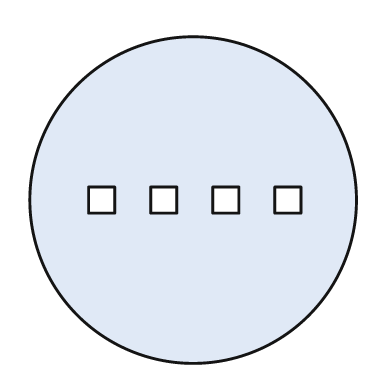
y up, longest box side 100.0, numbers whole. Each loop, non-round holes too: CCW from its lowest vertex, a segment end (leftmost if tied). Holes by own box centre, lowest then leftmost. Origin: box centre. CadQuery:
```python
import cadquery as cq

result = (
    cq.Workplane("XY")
    .moveTo(0.0, 0.0)
    .circle(50.0)
    .moveTo(-32.0, -4.0)
    .lineTo(-24.0, -4.0)
    .lineTo(-24.0, 4.0)
    .lineTo(-32.0, 4.0)
    .close()
    .moveTo(-13.0, -4.0)
    .lineTo(-5.0, -4.0)
    .lineTo(-5.0, 4.0)
    .lineTo(-13.0, 4.0)
    .close()
    .moveTo(6.0, -4.0)
    .lineTo(14.0, -4.0)
    .lineTo(14.0, 4.0)
    .lineTo(6.0, 4.0)
    .close()
    .moveTo(25.0, -4.0)
    .lineTo(33.0, -4.0)
    .lineTo(33.0, 4.0)
    .lineTo(25.0, 4.0)
    .close()
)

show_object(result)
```